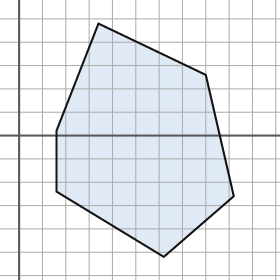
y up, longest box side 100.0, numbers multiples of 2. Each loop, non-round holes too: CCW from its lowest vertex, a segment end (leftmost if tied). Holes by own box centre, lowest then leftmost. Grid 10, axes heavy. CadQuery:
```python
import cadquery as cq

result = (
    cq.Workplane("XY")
    .moveTo(62.0, -52.0)
    .lineTo(92.0, -26.0)
    .lineTo(80.0, 26.0)
    .lineTo(34.0, 48.0)
    .lineTo(16.0, 2.0)
    .lineTo(16.0, -24.0)
    .close()
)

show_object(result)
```